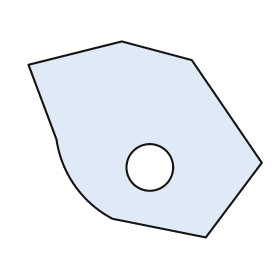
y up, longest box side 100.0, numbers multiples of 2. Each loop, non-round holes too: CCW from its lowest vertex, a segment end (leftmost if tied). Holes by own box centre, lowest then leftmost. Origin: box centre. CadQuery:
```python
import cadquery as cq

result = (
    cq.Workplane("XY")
    .moveTo(26.0, -42.0)
    .lineTo(50.0, -10.0)
    .lineTo(20.0, 34.0)
    .lineTo(-10.0, 42.0)
    .lineTo(-50.0, 32.0)
    .lineTo(-38.0, 0.0)
    .threePointArc((-30.0, -20.0), (-14.0, -34.0))
    .close()
    .moveTo(2.0, -12.0)
    .circle(10.0)
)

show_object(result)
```